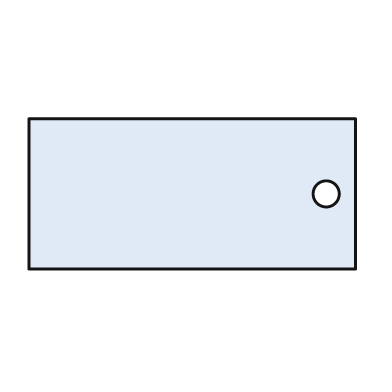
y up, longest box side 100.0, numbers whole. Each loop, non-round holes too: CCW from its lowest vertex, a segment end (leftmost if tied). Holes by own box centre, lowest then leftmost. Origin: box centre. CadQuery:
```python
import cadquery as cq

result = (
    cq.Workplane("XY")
    .moveTo(-50.0, -23.0)
    .lineTo(50.0, -23.0)
    .lineTo(50.0, 23.0)
    .lineTo(-50.0, 23.0)
    .close()
    .moveTo(41.0, 0.0)
    .circle(4.0)
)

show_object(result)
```